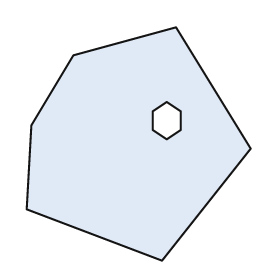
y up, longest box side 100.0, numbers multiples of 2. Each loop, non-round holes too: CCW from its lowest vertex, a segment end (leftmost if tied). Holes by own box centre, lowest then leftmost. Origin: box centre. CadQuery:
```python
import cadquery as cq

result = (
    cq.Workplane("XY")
    .moveTo(10.0, -50.0)
    .lineTo(48.0, -2.0)
    .lineTo(16.0, 50.0)
    .lineTo(-28.0, 38.0)
    .lineTo(-46.0, 8.0)
    .lineTo(-48.0, -28.0)
    .close()
    .moveTo(12.0, 2.0)
    .lineTo(18.0, 6.0)
    .lineTo(18.0, 14.0)
    .lineTo(12.0, 18.0)
    .lineTo(6.0, 14.0)
    .lineTo(6.0, 6.0)
    .close()
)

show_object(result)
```